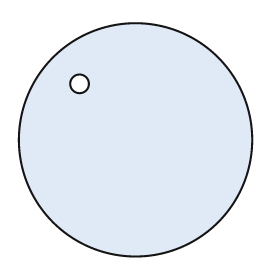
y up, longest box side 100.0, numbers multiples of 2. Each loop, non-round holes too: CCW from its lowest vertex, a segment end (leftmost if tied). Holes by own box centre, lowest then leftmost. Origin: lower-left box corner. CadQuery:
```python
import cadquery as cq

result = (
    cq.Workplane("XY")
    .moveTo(50.0, 50.0)
    .circle(50.0)
    .moveTo(26.0, 74.0)
    .circle(4.0)
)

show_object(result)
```